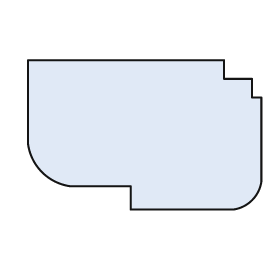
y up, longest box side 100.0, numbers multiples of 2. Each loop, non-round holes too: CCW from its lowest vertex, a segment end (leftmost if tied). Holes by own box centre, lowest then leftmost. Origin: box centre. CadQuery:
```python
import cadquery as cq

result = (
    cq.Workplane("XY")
    .moveTo(-6.0, -32.0)
    .lineTo(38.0, -32.0)
    .threePointArc((46.0, -28.0), (50.0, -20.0))
    .lineTo(50.0, 16.0)
    .lineTo(46.0, 16.0)
    .lineTo(46.0, 24.0)
    .lineTo(34.0, 24.0)
    .lineTo(34.0, 32.0)
    .lineTo(-50.0, 32.0)
    .lineTo(-50.0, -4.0)
    .threePointArc((-44.0, -16.0), (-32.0, -22.0))
    .lineTo(-6.0, -22.0)
    .close()
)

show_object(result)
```